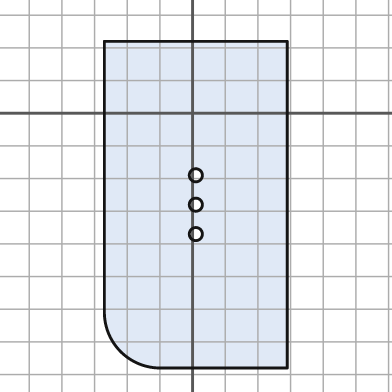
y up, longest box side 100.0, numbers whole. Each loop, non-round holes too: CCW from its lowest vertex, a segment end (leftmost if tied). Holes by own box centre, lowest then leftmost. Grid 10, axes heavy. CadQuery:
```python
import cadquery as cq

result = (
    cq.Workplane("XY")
    .moveTo(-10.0, -78.0)
    .lineTo(29.0, -78.0)
    .lineTo(29.0, 22.0)
    .lineTo(-27.0, 22.0)
    .lineTo(-27.0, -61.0)
    .threePointArc((-22.0, -73.0), (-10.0, -78.0))
    .close()
    .moveTo(1.0, -37.0)
    .circle(2.0)
    .moveTo(1.0, -28.0)
    .circle(2.0)
    .moveTo(1.0, -19.0)
    .circle(2.0)
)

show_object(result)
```